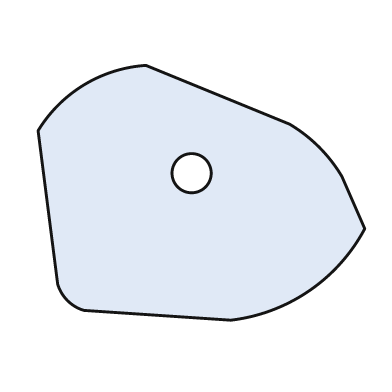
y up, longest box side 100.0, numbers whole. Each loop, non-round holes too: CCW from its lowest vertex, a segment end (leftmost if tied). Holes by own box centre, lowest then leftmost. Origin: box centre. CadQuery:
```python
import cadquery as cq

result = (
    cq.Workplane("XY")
    .moveTo(9.0, -39.0)
    .threePointArc((33.0, -30.0), (50.0, -11.0))
    .lineTo(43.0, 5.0)
    .threePointArc((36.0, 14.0), (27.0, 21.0))
    .lineTo(-17.0, 39.0)
    .threePointArc((-36.0, 33.0), (-50.0, 19.0))
    .lineTo(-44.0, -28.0)
    .threePointArc((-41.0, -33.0), (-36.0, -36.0))
    .close()
    .moveTo(-3.0, 6.0)
    .circle(6.0)
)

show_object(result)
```